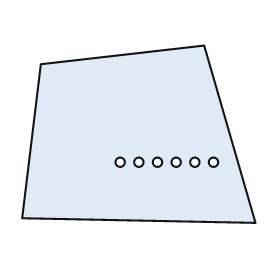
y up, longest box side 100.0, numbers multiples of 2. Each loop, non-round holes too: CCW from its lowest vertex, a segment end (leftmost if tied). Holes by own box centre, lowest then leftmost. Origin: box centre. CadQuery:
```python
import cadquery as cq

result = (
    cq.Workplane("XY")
    .moveTo(50.0, -38.0)
    .lineTo(28.0, 38.0)
    .lineTo(-42.0, 30.0)
    .lineTo(-50.0, -36.0)
    .close()
    .moveTo(-8.0, -12.0)
    .circle(2.0)
    .moveTo(0.0, -12.0)
    .circle(2.0)
    .moveTo(8.0, -12.0)
    .circle(2.0)
    .moveTo(16.0, -12.0)
    .circle(2.0)
    .moveTo(24.0, -12.0)
    .circle(2.0)
    .moveTo(32.0, -12.0)
    .circle(2.0)
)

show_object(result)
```